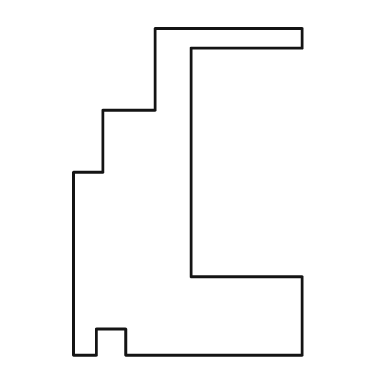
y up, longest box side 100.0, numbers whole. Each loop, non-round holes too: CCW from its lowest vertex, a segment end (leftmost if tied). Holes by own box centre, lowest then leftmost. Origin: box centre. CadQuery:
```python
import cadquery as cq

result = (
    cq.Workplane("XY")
    .moveTo(-35.0, -50.0)
    .lineTo(-28.0, -50.0)
    .lineTo(-28.0, -42.0)
    .lineTo(-19.0, -42.0)
    .lineTo(-19.0, -50.0)
    .lineTo(35.0, -50.0)
    .lineTo(35.0, -26.0)
    .lineTo(1.0, -26.0)
    .lineTo(1.0, 44.0)
    .lineTo(35.0, 44.0)
    .lineTo(35.0, 50.0)
    .lineTo(-10.0, 50.0)
    .lineTo(-10.0, 25.0)
    .lineTo(-26.0, 25.0)
    .lineTo(-26.0, 6.0)
    .lineTo(-35.0, 6.0)
    .close()
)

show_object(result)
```